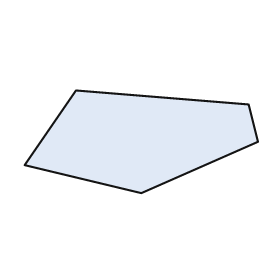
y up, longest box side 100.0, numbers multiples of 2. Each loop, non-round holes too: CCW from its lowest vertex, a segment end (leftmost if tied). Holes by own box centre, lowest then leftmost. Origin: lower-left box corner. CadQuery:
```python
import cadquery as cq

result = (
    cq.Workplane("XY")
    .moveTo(50.0, 0.0)
    .lineTo(100.0, 22.0)
    .lineTo(96.0, 38.0)
    .lineTo(22.0, 44.0)
    .lineTo(0.0, 12.0)
    .close()
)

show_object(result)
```